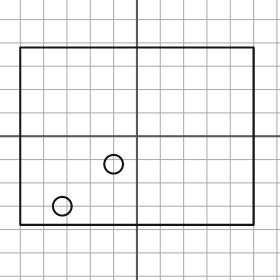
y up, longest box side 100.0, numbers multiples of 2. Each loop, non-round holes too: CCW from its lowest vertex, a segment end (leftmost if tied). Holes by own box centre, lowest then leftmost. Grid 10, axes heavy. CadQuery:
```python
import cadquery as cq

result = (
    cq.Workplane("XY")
    .moveTo(-50.0, -38.0)
    .lineTo(50.0, -38.0)
    .lineTo(50.0, 38.0)
    .lineTo(-50.0, 38.0)
    .close()
    .moveTo(-32.0, -30.0)
    .circle(4.0)
    .moveTo(-10.0, -12.0)
    .circle(4.0)
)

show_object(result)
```